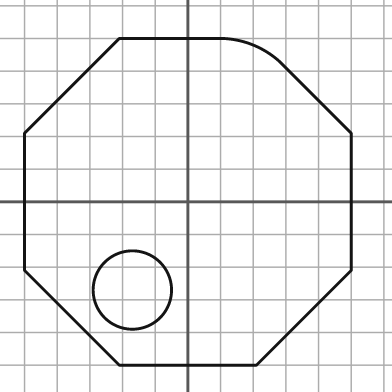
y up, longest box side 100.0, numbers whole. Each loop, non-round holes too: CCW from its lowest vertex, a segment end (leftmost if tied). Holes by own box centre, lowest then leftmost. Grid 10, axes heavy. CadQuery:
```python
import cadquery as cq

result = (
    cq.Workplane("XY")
    .moveTo(-21.0, -50.0)
    .lineTo(21.0, -50.0)
    .lineTo(50.0, -21.0)
    .lineTo(50.0, 21.0)
    .lineTo(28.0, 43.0)
    .threePointArc((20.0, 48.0), (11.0, 50.0))
    .lineTo(-21.0, 50.0)
    .lineTo(-50.0, 21.0)
    .lineTo(-50.0, -21.0)
    .close()
    .moveTo(-17.0, -27.0)
    .circle(12.0)
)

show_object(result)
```